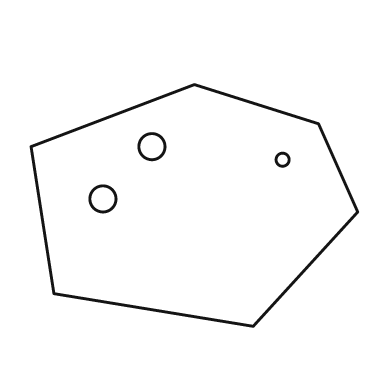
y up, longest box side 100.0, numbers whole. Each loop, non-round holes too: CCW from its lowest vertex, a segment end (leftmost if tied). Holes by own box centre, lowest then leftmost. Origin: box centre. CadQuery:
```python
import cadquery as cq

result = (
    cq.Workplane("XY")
    .moveTo(18.0, -37.0)
    .lineTo(50.0, -2.0)
    .lineTo(38.0, 25.0)
    .lineTo(0.0, 37.0)
    .lineTo(-50.0, 18.0)
    .lineTo(-43.0, -27.0)
    .close()
    .moveTo(-28.0, 2.0)
    .circle(4.0)
    .moveTo(27.0, 14.0)
    .circle(2.0)
    .moveTo(-13.0, 18.0)
    .circle(4.0)
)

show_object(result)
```